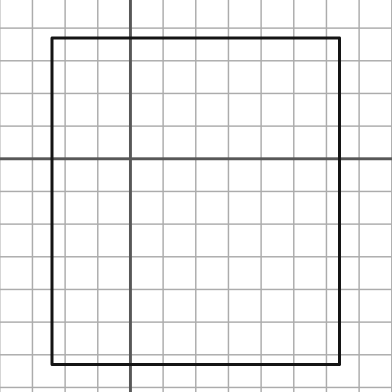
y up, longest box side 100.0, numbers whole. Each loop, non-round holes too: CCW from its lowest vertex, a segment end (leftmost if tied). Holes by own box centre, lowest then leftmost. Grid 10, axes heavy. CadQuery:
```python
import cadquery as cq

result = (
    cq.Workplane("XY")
    .moveTo(-24.0, -63.0)
    .lineTo(64.0, -63.0)
    .lineTo(64.0, 37.0)
    .lineTo(-24.0, 37.0)
    .close()
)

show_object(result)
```